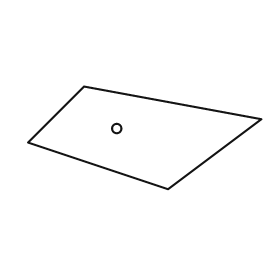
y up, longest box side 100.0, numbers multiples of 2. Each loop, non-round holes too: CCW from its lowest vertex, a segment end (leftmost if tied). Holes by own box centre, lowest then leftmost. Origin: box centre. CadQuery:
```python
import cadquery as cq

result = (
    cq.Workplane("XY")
    .moveTo(10.0, -22.0)
    .lineTo(50.0, 8.0)
    .lineTo(-26.0, 22.0)
    .lineTo(-50.0, -2.0)
    .close()
    .moveTo(-12.0, 4.0)
    .circle(2.0)
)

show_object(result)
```